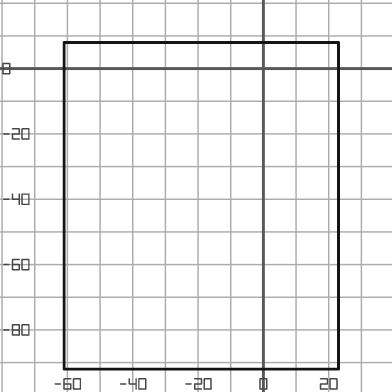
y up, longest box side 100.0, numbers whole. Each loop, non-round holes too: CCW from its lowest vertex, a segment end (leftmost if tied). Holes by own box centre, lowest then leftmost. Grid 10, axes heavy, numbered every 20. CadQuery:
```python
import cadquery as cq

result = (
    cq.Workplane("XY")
    .moveTo(-61.0, -92.0)
    .lineTo(23.0, -92.0)
    .lineTo(23.0, 8.0)
    .lineTo(-61.0, 8.0)
    .close()
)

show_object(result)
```